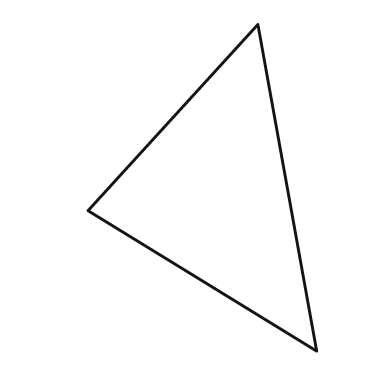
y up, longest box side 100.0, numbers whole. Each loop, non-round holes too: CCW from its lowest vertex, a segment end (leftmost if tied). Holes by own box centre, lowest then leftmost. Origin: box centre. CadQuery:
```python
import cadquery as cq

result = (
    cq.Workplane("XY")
    .moveTo(35.0, -50.0)
    .lineTo(17.0, 50.0)
    .lineTo(-35.0, -7.0)
    .close()
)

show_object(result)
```